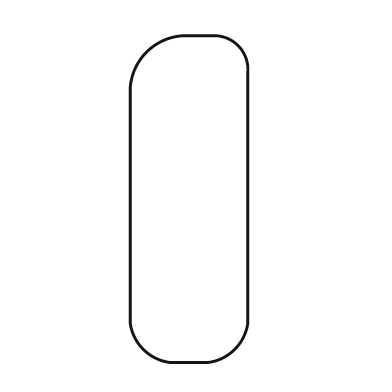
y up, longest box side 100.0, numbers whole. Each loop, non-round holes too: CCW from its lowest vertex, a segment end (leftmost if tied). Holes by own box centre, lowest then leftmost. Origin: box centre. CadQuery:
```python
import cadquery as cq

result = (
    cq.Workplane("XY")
    .moveTo(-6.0, -50.0)
    .lineTo(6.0, -50.0)
    .threePointArc((14.0, -46.0), (18.0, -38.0))
    .lineTo(18.0, 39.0)
    .threePointArc((15.0, 47.0), (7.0, 50.0))
    .lineTo(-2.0, 50.0)
    .threePointArc((-13.0, 45.0), (-18.0, 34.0))
    .lineTo(-18.0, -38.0)
    .threePointArc((-14.0, -46.0), (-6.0, -50.0))
    .close()
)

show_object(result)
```